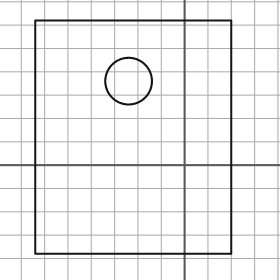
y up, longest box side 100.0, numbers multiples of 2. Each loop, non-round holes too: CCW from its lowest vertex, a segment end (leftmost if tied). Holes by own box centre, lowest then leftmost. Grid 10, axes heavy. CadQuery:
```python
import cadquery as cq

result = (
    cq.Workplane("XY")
    .moveTo(-64.0, -38.0)
    .lineTo(20.0, -38.0)
    .lineTo(20.0, 62.0)
    .lineTo(-64.0, 62.0)
    .close()
    .moveTo(-24.0, 36.0)
    .circle(10.0)
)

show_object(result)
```